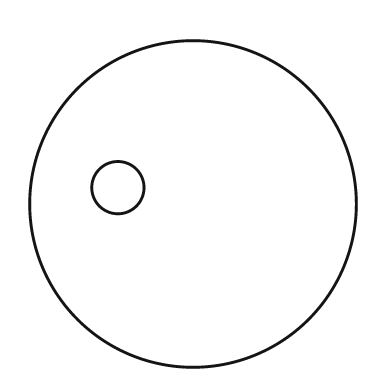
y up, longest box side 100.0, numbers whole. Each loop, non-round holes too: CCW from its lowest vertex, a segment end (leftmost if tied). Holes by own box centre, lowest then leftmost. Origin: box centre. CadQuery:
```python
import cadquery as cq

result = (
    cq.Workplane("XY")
    .moveTo(0.0, 0.0)
    .circle(50.0)
    .moveTo(-23.0, 5.0)
    .circle(8.0)
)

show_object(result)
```